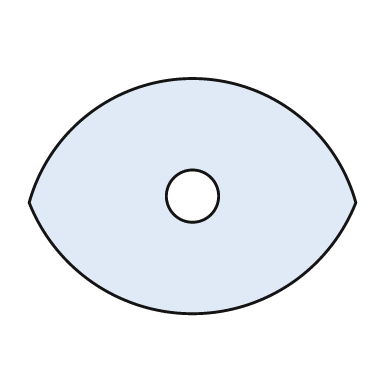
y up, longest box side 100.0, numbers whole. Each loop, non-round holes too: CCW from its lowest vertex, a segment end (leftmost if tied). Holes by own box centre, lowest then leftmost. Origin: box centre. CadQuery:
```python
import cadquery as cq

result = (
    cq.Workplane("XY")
    .moveTo(-50.0, -2.0)
    .threePointArc((0.0, -36.0), (50.0, -2.0))
    .threePointArc((0.0, 36.0), (-50.0, -2.0))
    .close()
    .moveTo(0.0, 0.0)
    .circle(8.0)
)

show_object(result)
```